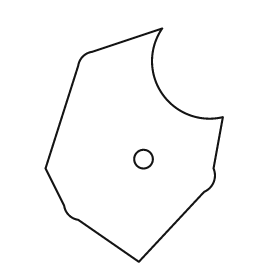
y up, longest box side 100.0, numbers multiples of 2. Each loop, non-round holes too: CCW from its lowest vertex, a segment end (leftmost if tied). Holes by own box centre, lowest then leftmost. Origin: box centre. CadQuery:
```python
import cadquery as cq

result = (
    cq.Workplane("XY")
    .moveTo(2.0, -50.0)
    .lineTo(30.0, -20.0)
    .threePointArc((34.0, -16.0), (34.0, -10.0))
    .lineTo(38.0, 12.0)
    .threePointArc((12.0, 22.0), (12.0, 50.0))
    .lineTo(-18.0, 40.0)
    .threePointArc((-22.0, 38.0), (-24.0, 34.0))
    .lineTo(-38.0, -10.0)
    .lineTo(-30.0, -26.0)
    .threePointArc((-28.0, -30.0), (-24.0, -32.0))
    .close()
    .moveTo(4.0, -6.0)
    .circle(4.0)
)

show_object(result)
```